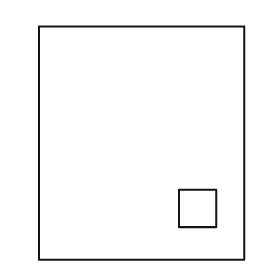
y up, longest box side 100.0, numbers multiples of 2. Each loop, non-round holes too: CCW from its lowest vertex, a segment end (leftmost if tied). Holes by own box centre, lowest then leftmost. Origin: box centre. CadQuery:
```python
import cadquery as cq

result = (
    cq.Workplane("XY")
    .moveTo(-44.0, -50.0)
    .lineTo(44.0, -50.0)
    .lineTo(44.0, 50.0)
    .lineTo(-44.0, 50.0)
    .close()
    .moveTo(16.0, -36.0)
    .lineTo(32.0, -36.0)
    .lineTo(32.0, -20.0)
    .lineTo(16.0, -20.0)
    .close()
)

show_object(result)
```